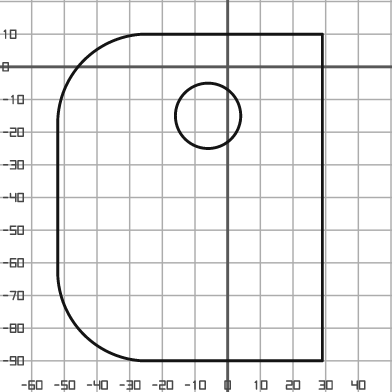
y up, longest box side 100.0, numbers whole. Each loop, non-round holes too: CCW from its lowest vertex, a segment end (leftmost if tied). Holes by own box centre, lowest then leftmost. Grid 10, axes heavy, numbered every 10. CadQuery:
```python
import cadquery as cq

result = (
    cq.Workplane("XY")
    .moveTo(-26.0, -90.0)
    .lineTo(29.0, -90.0)
    .lineTo(29.0, 10.0)
    .lineTo(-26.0, 10.0)
    .threePointArc((-44.0, 2.0), (-52.0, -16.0))
    .lineTo(-52.0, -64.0)
    .threePointArc((-44.0, -82.0), (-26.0, -90.0))
    .close()
    .moveTo(-6.0, -15.0)
    .circle(10.0)
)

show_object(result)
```